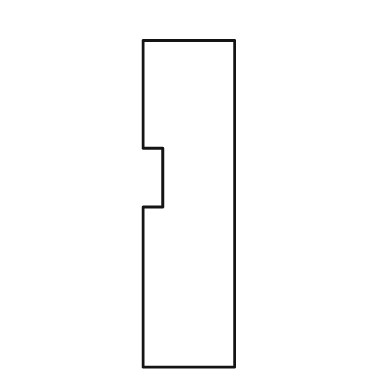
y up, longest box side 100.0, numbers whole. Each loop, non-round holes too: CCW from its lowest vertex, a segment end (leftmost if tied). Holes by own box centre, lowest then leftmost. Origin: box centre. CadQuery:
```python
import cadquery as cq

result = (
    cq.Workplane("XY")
    .moveTo(-14.0, -50.0)
    .lineTo(14.0, -50.0)
    .lineTo(14.0, 50.0)
    .lineTo(-14.0, 50.0)
    .lineTo(-14.0, 17.0)
    .lineTo(-8.0, 17.0)
    .lineTo(-8.0, -1.0)
    .lineTo(-14.0, -1.0)
    .close()
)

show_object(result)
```